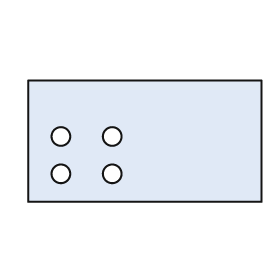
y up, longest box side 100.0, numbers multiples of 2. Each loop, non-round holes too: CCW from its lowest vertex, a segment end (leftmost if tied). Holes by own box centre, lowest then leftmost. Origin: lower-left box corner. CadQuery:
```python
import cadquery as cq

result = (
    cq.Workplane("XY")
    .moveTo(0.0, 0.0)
    .lineTo(100.0, 0.0)
    .lineTo(100.0, 52.0)
    .lineTo(0.0, 52.0)
    .close()
    .moveTo(14.0, 12.0)
    .circle(4.0)
    .moveTo(36.0, 12.0)
    .circle(4.0)
    .moveTo(14.0, 28.0)
    .circle(4.0)
    .moveTo(36.0, 28.0)
    .circle(4.0)
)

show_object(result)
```